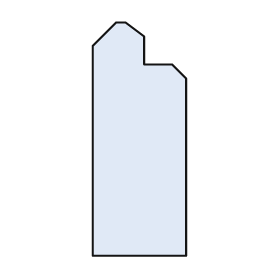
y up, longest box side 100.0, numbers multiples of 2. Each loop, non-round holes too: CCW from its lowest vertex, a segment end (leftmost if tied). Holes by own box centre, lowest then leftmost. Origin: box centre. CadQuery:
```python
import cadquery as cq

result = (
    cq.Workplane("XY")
    .moveTo(-20.0, -50.0)
    .lineTo(20.0, -50.0)
    .lineTo(20.0, 26.0)
    .lineTo(14.0, 32.0)
    .lineTo(2.0, 32.0)
    .lineTo(2.0, 44.0)
    .lineTo(-6.0, 50.0)
    .lineTo(-10.0, 50.0)
    .lineTo(-20.0, 40.0)
    .close()
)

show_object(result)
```